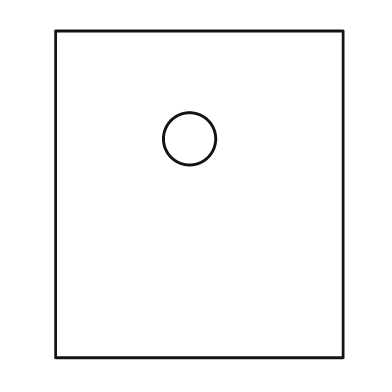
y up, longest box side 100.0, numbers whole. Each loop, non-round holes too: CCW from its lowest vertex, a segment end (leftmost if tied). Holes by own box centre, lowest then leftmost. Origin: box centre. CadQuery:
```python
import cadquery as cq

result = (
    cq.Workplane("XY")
    .moveTo(-44.0, -50.0)
    .lineTo(44.0, -50.0)
    .lineTo(44.0, 50.0)
    .lineTo(-44.0, 50.0)
    .close()
    .moveTo(-3.0, 17.0)
    .circle(8.0)
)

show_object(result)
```